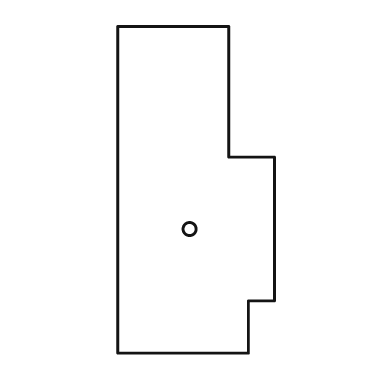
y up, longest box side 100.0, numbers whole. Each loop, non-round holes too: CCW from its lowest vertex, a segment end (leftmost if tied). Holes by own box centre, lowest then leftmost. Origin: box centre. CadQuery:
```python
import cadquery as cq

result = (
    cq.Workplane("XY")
    .moveTo(-24.0, -50.0)
    .lineTo(16.0, -50.0)
    .lineTo(16.0, -34.0)
    .lineTo(24.0, -34.0)
    .lineTo(24.0, 10.0)
    .lineTo(10.0, 10.0)
    .lineTo(10.0, 50.0)
    .lineTo(-24.0, 50.0)
    .close()
    .moveTo(-2.0, -12.0)
    .circle(2.0)
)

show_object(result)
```